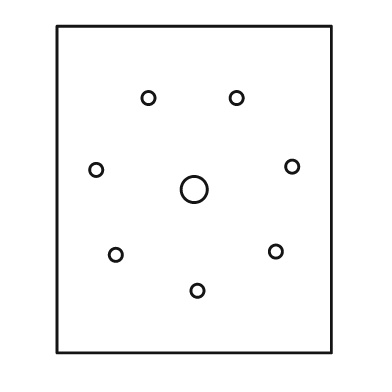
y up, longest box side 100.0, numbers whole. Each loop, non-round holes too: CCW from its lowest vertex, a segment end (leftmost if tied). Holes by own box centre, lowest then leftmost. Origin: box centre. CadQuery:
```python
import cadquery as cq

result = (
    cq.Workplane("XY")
    .moveTo(-42.0, -50.0)
    .lineTo(42.0, -50.0)
    .lineTo(42.0, 50.0)
    .lineTo(-42.0, 50.0)
    .close()
    .moveTo(1.0, -31.0)
    .circle(2.0)
    .moveTo(-24.0, -20.0)
    .circle(2.0)
    .moveTo(25.0, -19.0)
    .circle(2.0)
    .moveTo(0.0, 0.0)
    .circle(4.0)
    .moveTo(-30.0, 6.0)
    .circle(2.0)
    .moveTo(30.0, 7.0)
    .circle(2.0)
    .moveTo(-14.0, 28.0)
    .circle(2.0)
    .moveTo(13.0, 28.0)
    .circle(2.0)
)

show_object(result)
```